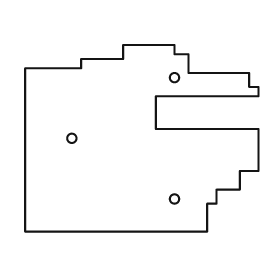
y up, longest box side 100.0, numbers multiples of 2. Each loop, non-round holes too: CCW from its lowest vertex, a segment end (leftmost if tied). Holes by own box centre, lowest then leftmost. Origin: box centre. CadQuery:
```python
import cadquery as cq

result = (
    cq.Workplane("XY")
    .moveTo(-50.0, -40.0)
    .lineTo(28.0, -40.0)
    .lineTo(28.0, -28.0)
    .lineTo(32.0, -28.0)
    .lineTo(32.0, -22.0)
    .lineTo(42.0, -22.0)
    .lineTo(42.0, -14.0)
    .lineTo(50.0, -14.0)
    .lineTo(50.0, 4.0)
    .lineTo(6.0, 4.0)
    .lineTo(6.0, 18.0)
    .lineTo(50.0, 18.0)
    .lineTo(50.0, 22.0)
    .lineTo(46.0, 22.0)
    .lineTo(46.0, 28.0)
    .lineTo(20.0, 28.0)
    .lineTo(20.0, 36.0)
    .lineTo(14.0, 36.0)
    .lineTo(14.0, 40.0)
    .lineTo(-8.0, 40.0)
    .lineTo(-8.0, 34.0)
    .lineTo(-26.0, 34.0)
    .lineTo(-26.0, 30.0)
    .lineTo(-50.0, 30.0)
    .close()
    .moveTo(14.0, -26.0)
    .circle(2.0)
    .moveTo(-30.0, 0.0)
    .circle(2.0)
    .moveTo(14.0, 26.0)
    .circle(2.0)
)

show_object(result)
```